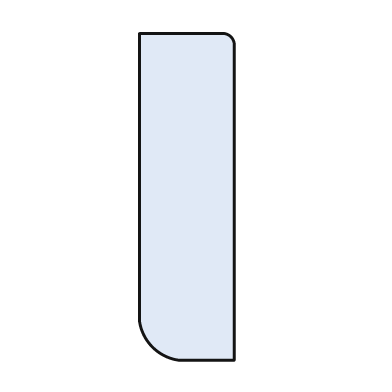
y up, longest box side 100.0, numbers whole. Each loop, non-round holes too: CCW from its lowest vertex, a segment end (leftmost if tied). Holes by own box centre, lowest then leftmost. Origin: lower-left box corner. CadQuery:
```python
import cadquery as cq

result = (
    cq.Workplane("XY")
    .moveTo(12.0, 0.0)
    .lineTo(29.0, 0.0)
    .lineTo(29.0, 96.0)
    .threePointArc((28.0, 99.0), (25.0, 100.0))
    .lineTo(0.0, 100.0)
    .lineTo(0.0, 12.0)
    .threePointArc((4.0, 4.0), (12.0, 0.0))
    .close()
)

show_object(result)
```